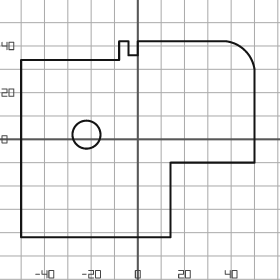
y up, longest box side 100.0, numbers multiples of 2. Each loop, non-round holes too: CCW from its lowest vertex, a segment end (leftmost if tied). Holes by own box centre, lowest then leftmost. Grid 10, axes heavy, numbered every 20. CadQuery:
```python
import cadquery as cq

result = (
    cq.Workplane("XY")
    .moveTo(-50.0, -42.0)
    .lineTo(14.0, -42.0)
    .lineTo(14.0, -10.0)
    .lineTo(50.0, -10.0)
    .lineTo(50.0, 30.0)
    .threePointArc((46.0, 38.0), (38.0, 42.0))
    .lineTo(0.0, 42.0)
    .lineTo(0.0, 36.0)
    .lineTo(-4.0, 36.0)
    .lineTo(-4.0, 42.0)
    .lineTo(-8.0, 42.0)
    .lineTo(-8.0, 34.0)
    .lineTo(-50.0, 34.0)
    .close()
    .moveTo(-22.0, 2.0)
    .circle(6.0)
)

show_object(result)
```